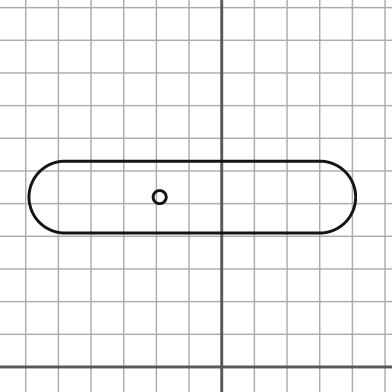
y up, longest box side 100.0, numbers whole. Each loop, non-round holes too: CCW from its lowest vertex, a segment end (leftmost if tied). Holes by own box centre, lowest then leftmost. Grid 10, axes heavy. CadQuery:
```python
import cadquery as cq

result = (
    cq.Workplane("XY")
    .moveTo(-48.0, 41.0)
    .lineTo(30.0, 41.0)
    .threePointArc((41.0, 52.0), (30.0, 63.0))
    .lineTo(-48.0, 63.0)
    .threePointArc((-59.0, 52.0), (-48.0, 41.0))
    .close()
    .moveTo(-19.0, 52.0)
    .circle(2.0)
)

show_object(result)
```